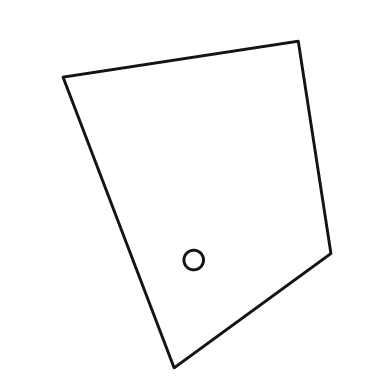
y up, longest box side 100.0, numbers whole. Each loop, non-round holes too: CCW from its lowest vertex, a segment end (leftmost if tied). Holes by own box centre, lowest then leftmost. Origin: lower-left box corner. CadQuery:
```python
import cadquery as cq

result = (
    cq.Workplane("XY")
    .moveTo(34.0, 0.0)
    .lineTo(82.0, 35.0)
    .lineTo(72.0, 100.0)
    .lineTo(0.0, 89.0)
    .close()
    .moveTo(40.0, 33.0)
    .circle(3.0)
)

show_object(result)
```